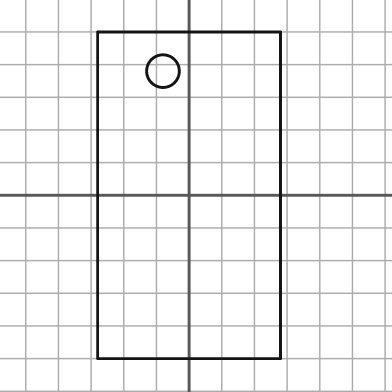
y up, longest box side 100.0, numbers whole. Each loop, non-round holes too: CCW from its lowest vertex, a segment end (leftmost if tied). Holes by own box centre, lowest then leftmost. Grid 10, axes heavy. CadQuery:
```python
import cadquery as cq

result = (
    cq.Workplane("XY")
    .moveTo(-28.0, -50.0)
    .lineTo(28.0, -50.0)
    .lineTo(28.0, 50.0)
    .lineTo(-28.0, 50.0)
    .close()
    .moveTo(-8.0, 38.0)
    .circle(5.0)
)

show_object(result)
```